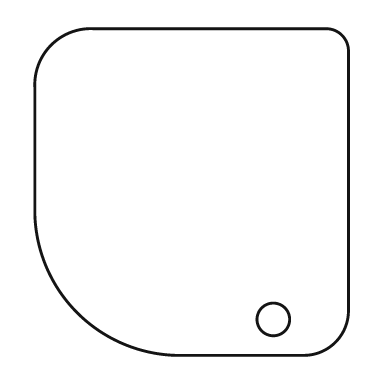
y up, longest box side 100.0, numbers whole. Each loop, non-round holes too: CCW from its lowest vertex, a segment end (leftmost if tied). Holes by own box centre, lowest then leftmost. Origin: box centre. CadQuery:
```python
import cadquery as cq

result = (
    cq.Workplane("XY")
    .moveTo(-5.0, -50.0)
    .lineTo(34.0, -50.0)
    .threePointArc((44.0, -46.0), (48.0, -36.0))
    .lineTo(48.0, 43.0)
    .threePointArc((46.0, 48.0), (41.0, 50.0))
    .lineTo(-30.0, 50.0)
    .threePointArc((-43.0, 45.0), (-48.0, 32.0))
    .lineTo(-48.0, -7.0)
    .threePointArc((-35.0, -37.0), (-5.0, -50.0))
    .close()
    .moveTo(25.0, -39.0)
    .circle(5.0)
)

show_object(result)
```